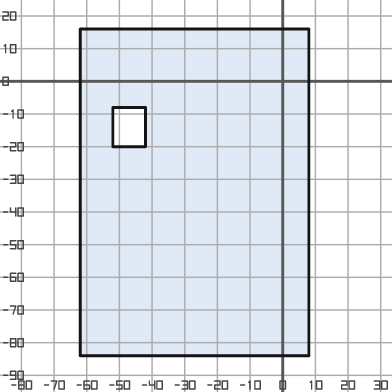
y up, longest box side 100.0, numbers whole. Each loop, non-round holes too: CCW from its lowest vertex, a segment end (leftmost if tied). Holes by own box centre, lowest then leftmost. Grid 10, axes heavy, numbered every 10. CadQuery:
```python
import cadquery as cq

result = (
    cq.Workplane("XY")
    .moveTo(-62.0, -84.0)
    .lineTo(8.0, -84.0)
    .lineTo(8.0, 16.0)
    .lineTo(-62.0, 16.0)
    .close()
    .moveTo(-52.0, -20.0)
    .lineTo(-42.0, -20.0)
    .lineTo(-42.0, -8.0)
    .lineTo(-52.0, -8.0)
    .close()
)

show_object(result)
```